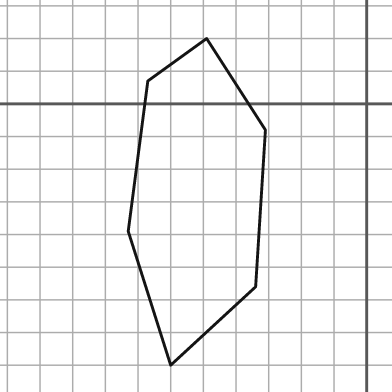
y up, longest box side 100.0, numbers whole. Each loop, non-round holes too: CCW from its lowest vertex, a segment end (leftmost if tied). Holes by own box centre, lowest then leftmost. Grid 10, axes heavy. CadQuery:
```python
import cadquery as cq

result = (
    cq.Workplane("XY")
    .moveTo(-60.0, -80.0)
    .lineTo(-34.0, -56.0)
    .lineTo(-31.0, -8.0)
    .lineTo(-49.0, 20.0)
    .lineTo(-67.0, 7.0)
    .lineTo(-73.0, -39.0)
    .close()
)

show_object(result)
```